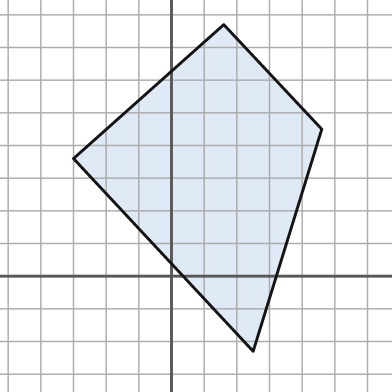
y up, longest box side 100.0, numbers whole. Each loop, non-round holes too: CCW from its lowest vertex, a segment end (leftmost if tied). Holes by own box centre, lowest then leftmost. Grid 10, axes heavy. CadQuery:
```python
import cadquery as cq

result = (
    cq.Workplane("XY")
    .moveTo(25.0, -23.0)
    .lineTo(46.0, 45.0)
    .lineTo(16.0, 77.0)
    .lineTo(-30.0, 36.0)
    .close()
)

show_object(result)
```